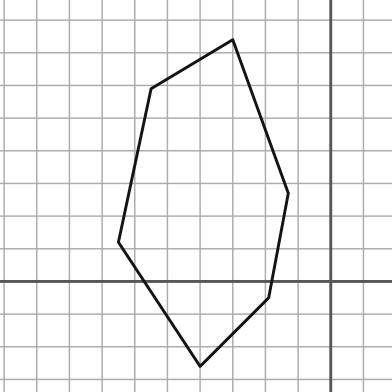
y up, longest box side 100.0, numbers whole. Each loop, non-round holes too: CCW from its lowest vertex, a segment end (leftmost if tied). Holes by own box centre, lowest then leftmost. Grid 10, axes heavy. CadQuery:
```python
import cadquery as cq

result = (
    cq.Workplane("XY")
    .moveTo(-40.0, -26.0)
    .lineTo(-19.0, -5.0)
    .lineTo(-13.0, 27.0)
    .lineTo(-30.0, 74.0)
    .lineTo(-55.0, 59.0)
    .lineTo(-65.0, 12.0)
    .close()
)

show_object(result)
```